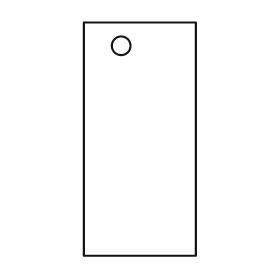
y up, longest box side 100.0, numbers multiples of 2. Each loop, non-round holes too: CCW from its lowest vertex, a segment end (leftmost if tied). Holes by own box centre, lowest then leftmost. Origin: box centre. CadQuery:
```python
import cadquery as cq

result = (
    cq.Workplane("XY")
    .moveTo(-24.0, -50.0)
    .lineTo(24.0, -50.0)
    .lineTo(24.0, 50.0)
    .lineTo(-24.0, 50.0)
    .close()
    .moveTo(-8.0, 40.0)
    .circle(4.0)
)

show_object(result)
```